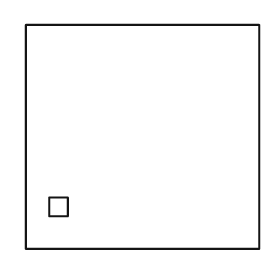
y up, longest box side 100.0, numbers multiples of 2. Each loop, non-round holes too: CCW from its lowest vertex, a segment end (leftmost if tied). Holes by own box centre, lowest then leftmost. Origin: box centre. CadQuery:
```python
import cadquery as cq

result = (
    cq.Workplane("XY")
    .moveTo(-50.0, -48.0)
    .lineTo(50.0, -48.0)
    .lineTo(50.0, 48.0)
    .lineTo(-50.0, 48.0)
    .close()
    .moveTo(-40.0, -34.0)
    .lineTo(-32.0, -34.0)
    .lineTo(-32.0, -26.0)
    .lineTo(-40.0, -26.0)
    .close()
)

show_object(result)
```